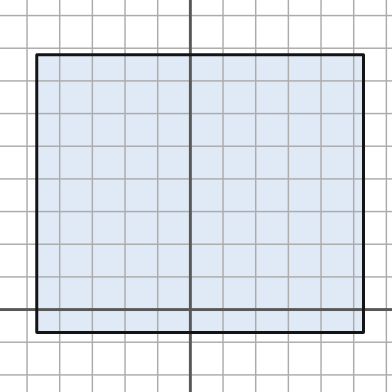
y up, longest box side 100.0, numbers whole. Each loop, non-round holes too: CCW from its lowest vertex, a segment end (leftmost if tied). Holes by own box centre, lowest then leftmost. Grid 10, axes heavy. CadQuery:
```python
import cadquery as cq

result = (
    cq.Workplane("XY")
    .moveTo(-47.0, -7.0)
    .lineTo(53.0, -7.0)
    .lineTo(53.0, 78.0)
    .lineTo(-47.0, 78.0)
    .close()
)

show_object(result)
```